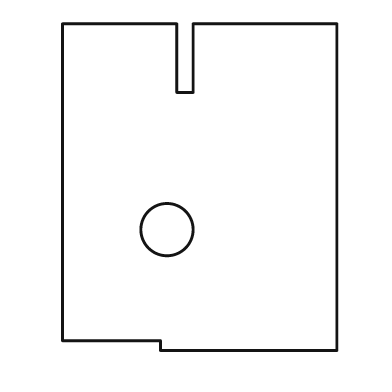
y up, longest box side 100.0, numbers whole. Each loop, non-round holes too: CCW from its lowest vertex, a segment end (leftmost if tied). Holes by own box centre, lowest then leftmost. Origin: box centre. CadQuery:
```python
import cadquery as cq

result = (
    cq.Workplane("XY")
    .moveTo(-12.0, -50.0)
    .lineTo(42.0, -50.0)
    .lineTo(42.0, 50.0)
    .lineTo(-2.0, 50.0)
    .lineTo(-2.0, 29.0)
    .lineTo(-7.0, 29.0)
    .lineTo(-7.0, 50.0)
    .lineTo(-42.0, 50.0)
    .lineTo(-42.0, -47.0)
    .lineTo(-12.0, -47.0)
    .close()
    .moveTo(-10.0, -13.0)
    .circle(8.0)
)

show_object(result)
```